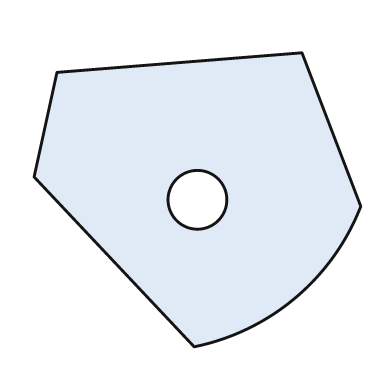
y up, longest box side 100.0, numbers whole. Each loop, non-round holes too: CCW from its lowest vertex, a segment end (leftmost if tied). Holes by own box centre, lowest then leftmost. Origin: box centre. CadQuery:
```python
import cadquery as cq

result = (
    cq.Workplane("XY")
    .moveTo(-1.0, -45.0)
    .threePointArc((30.0, -30.0), (50.0, -2.0))
    .lineTo(32.0, 45.0)
    .lineTo(-43.0, 39.0)
    .lineTo(-50.0, 7.0)
    .close()
    .moveTo(0.0, 0.0)
    .circle(9.0)
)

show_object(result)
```